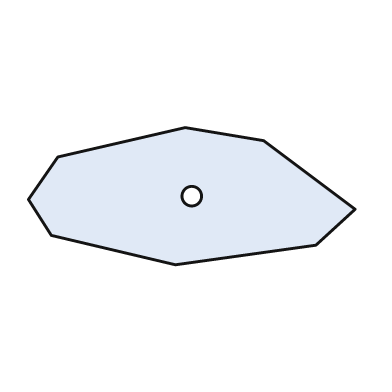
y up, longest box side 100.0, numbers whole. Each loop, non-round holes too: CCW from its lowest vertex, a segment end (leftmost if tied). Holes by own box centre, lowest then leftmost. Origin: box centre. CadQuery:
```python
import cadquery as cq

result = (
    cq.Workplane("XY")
    .moveTo(-5.0, -21.0)
    .lineTo(38.0, -15.0)
    .lineTo(50.0, -4.0)
    .lineTo(22.0, 17.0)
    .lineTo(-2.0, 21.0)
    .lineTo(-41.0, 12.0)
    .lineTo(-50.0, -1.0)
    .lineTo(-43.0, -12.0)
    .close()
    .moveTo(0.0, 0.0)
    .circle(3.0)
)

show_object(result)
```